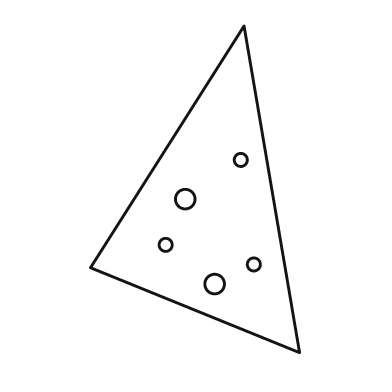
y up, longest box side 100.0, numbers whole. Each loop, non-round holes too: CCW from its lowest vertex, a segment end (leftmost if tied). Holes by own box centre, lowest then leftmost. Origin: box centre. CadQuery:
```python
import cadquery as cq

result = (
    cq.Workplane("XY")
    .moveTo(32.0, -50.0)
    .lineTo(15.0, 50.0)
    .lineTo(-32.0, -24.0)
    .close()
    .moveTo(6.0, -29.0)
    .circle(3.0)
    .moveTo(18.0, -23.0)
    .circle(2.0)
    .moveTo(-9.0, -17.0)
    .circle(2.0)
    .moveTo(-3.0, -3.0)
    .circle(3.0)
    .moveTo(14.0, 9.0)
    .circle(2.0)
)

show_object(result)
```